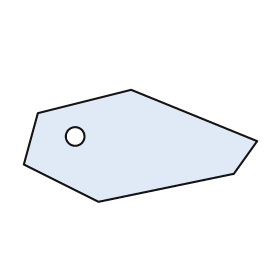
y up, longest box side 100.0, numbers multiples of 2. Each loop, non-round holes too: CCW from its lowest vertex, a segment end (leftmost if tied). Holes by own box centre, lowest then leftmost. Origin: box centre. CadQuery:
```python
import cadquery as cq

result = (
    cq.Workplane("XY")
    .moveTo(-18.0, -24.0)
    .lineTo(40.0, -12.0)
    .lineTo(50.0, 2.0)
    .lineTo(-4.0, 24.0)
    .lineTo(-44.0, 14.0)
    .lineTo(-50.0, -8.0)
    .close()
    .moveTo(-28.0, 4.0)
    .circle(4.0)
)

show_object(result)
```